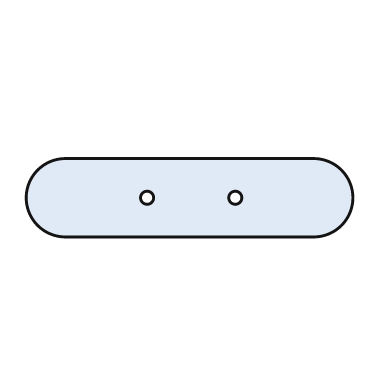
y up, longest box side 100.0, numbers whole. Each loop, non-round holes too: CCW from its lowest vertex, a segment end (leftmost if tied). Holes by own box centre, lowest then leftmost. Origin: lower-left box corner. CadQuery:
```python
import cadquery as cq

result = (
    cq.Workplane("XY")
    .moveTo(12.0, 0.0)
    .lineTo(88.0, 0.0)
    .threePointArc((100.0, 12.0), (88.0, 24.0))
    .lineTo(12.0, 24.0)
    .threePointArc((0.0, 12.0), (12.0, 0.0))
    .close()
    .moveTo(37.0, 12.0)
    .circle(2.0)
    .moveTo(64.0, 12.0)
    .circle(2.0)
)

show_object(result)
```